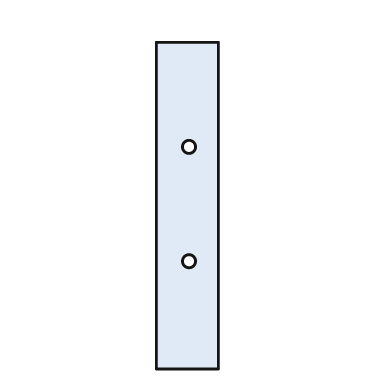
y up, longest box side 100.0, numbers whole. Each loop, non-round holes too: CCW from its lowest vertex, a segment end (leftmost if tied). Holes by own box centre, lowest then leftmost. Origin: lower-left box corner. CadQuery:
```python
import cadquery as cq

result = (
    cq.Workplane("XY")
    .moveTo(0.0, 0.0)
    .lineTo(19.0, 0.0)
    .lineTo(19.0, 100.0)
    .lineTo(0.0, 100.0)
    .close()
    .moveTo(10.0, 33.0)
    .circle(2.0)
    .moveTo(10.0, 68.0)
    .circle(2.0)
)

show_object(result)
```